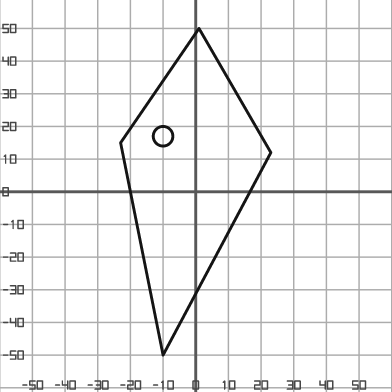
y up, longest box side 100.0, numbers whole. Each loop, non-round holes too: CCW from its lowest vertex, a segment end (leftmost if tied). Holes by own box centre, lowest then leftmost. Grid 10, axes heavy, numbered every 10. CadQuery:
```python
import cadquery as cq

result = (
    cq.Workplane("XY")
    .moveTo(-10.0, -50.0)
    .lineTo(23.0, 12.0)
    .lineTo(1.0, 50.0)
    .lineTo(-23.0, 15.0)
    .close()
    .moveTo(-10.0, 17.0)
    .circle(3.0)
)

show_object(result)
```